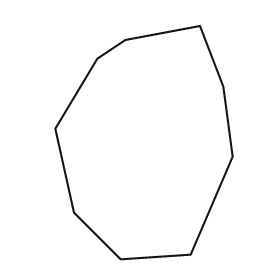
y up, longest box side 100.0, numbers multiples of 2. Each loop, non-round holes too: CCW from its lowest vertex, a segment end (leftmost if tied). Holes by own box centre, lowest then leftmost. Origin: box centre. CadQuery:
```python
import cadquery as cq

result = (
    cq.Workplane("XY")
    .moveTo(-10.0, -50.0)
    .lineTo(20.0, -48.0)
    .lineTo(38.0, -6.0)
    .lineTo(34.0, 24.0)
    .lineTo(24.0, 50.0)
    .lineTo(-8.0, 44.0)
    .lineTo(-20.0, 36.0)
    .lineTo(-38.0, 6.0)
    .lineTo(-30.0, -30.0)
    .close()
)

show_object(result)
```